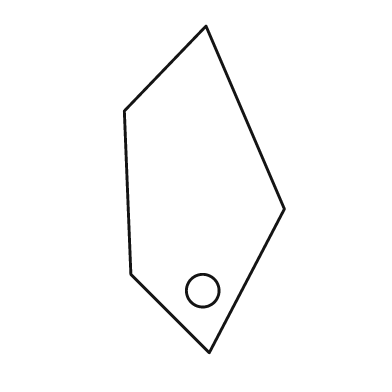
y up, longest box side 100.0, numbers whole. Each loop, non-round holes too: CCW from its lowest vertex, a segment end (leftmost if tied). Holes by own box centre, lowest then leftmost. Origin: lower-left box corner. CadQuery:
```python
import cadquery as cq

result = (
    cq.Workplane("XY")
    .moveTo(26.0, 0.0)
    .lineTo(49.0, 44.0)
    .lineTo(25.0, 100.0)
    .lineTo(0.0, 74.0)
    .lineTo(2.0, 24.0)
    .close()
    .moveTo(24.0, 19.0)
    .circle(5.0)
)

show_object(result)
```